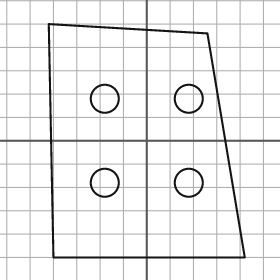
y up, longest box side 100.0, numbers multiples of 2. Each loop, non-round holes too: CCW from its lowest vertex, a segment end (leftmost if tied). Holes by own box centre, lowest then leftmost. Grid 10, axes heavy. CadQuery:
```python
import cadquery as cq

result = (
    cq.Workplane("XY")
    .moveTo(-40.0, -50.0)
    .lineTo(42.0, -50.0)
    .lineTo(26.0, 46.0)
    .lineTo(-42.0, 50.0)
    .close()
    .moveTo(-18.0, -18.0)
    .circle(6.0)
    .moveTo(18.0, -18.0)
    .circle(6.0)
    .moveTo(-18.0, 18.0)
    .circle(6.0)
    .moveTo(18.0, 18.0)
    .circle(6.0)
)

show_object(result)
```